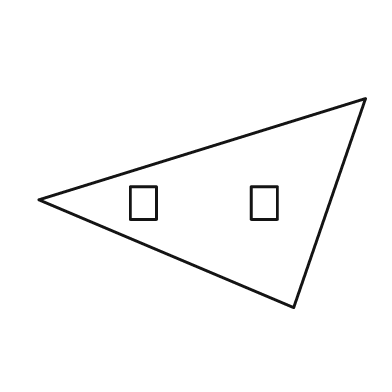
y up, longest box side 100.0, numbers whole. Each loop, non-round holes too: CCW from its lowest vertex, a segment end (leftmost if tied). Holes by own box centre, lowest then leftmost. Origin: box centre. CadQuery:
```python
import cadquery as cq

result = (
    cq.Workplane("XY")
    .moveTo(28.0, -32.0)
    .lineTo(50.0, 32.0)
    .lineTo(-50.0, 1.0)
    .close()
    .moveTo(-22.0, -5.0)
    .lineTo(-14.0, -5.0)
    .lineTo(-14.0, 5.0)
    .lineTo(-22.0, 5.0)
    .close()
    .moveTo(15.0, -5.0)
    .lineTo(23.0, -5.0)
    .lineTo(23.0, 5.0)
    .lineTo(15.0, 5.0)
    .close()
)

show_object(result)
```